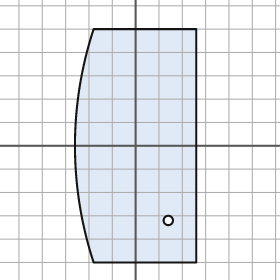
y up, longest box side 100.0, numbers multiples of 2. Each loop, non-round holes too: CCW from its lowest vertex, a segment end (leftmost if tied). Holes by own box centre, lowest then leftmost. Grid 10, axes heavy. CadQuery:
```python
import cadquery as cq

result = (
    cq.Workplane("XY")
    .moveTo(-18.0, -50.0)
    .lineTo(26.0, -50.0)
    .lineTo(26.0, 50.0)
    .lineTo(-18.0, 50.0)
    .threePointArc((-26.0, 0.0), (-18.0, -50.0))
    .close()
    .moveTo(14.0, -32.0)
    .circle(2.0)
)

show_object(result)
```